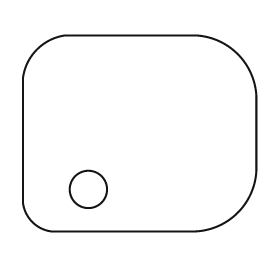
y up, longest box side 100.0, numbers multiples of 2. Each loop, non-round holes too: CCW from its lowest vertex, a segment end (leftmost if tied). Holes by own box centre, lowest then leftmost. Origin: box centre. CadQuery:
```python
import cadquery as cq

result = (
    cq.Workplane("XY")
    .moveTo(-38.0, -42.0)
    .lineTo(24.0, -42.0)
    .threePointArc((42.0, -34.0), (50.0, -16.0))
    .lineTo(50.0, 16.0)
    .threePointArc((42.0, 34.0), (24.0, 42.0))
    .lineTo(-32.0, 42.0)
    .threePointArc((-44.0, 36.0), (-50.0, 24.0))
    .lineTo(-50.0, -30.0)
    .threePointArc((-46.0, -38.0), (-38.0, -42.0))
    .close()
    .moveTo(-22.0, -24.0)
    .circle(8.0)
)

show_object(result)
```